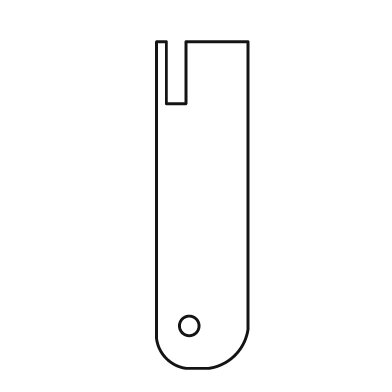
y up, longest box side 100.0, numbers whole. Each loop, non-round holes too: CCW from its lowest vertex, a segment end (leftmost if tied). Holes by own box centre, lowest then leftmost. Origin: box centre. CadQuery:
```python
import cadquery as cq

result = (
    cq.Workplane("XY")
    .moveTo(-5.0, -50.0)
    .lineTo(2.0, -50.0)
    .threePointArc((10.0, -46.0), (14.0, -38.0))
    .lineTo(14.0, 50.0)
    .lineTo(-5.0, 50.0)
    .lineTo(-5.0, 31.0)
    .lineTo(-11.0, 31.0)
    .lineTo(-11.0, 50.0)
    .lineTo(-14.0, 50.0)
    .lineTo(-14.0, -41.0)
    .threePointArc((-11.0, -47.0), (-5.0, -50.0))
    .close()
    .moveTo(-4.0, -37.0)
    .circle(3.0)
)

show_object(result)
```